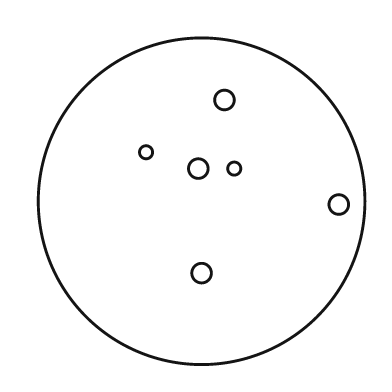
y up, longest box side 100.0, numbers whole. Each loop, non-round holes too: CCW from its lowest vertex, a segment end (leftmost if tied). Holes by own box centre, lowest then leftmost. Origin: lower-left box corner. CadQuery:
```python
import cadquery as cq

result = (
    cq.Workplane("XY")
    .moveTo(50.0, 50.0)
    .circle(50.0)
    .moveTo(50.0, 28.0)
    .circle(3.0)
    .moveTo(92.0, 49.0)
    .circle(3.0)
    .moveTo(49.0, 60.0)
    .circle(3.0)
    .moveTo(60.0, 60.0)
    .circle(2.0)
    .moveTo(33.0, 65.0)
    .circle(2.0)
    .moveTo(57.0, 81.0)
    .circle(3.0)
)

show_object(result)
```